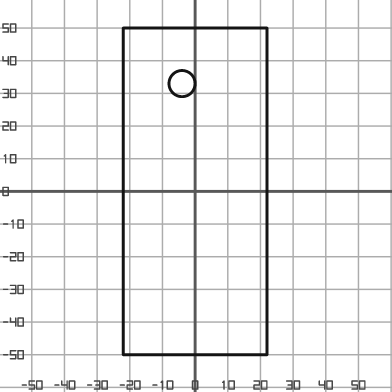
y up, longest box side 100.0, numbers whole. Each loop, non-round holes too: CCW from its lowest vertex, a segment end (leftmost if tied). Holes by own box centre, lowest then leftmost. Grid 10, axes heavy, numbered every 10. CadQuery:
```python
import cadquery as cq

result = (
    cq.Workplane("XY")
    .moveTo(-22.0, -50.0)
    .lineTo(22.0, -50.0)
    .lineTo(22.0, 50.0)
    .lineTo(-22.0, 50.0)
    .close()
    .moveTo(-4.0, 33.0)
    .circle(4.0)
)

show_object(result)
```